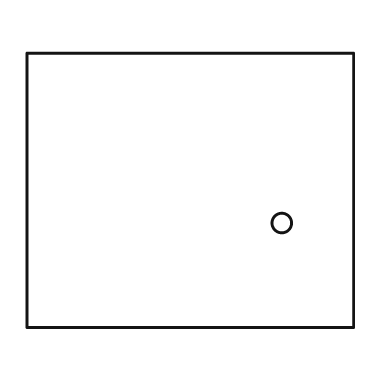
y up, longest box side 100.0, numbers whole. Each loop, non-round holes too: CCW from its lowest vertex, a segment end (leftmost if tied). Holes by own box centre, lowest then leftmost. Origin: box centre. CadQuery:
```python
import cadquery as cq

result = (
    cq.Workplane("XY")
    .moveTo(-50.0, -42.0)
    .lineTo(50.0, -42.0)
    .lineTo(50.0, 42.0)
    .lineTo(-50.0, 42.0)
    .close()
    .moveTo(28.0, -10.0)
    .circle(3.0)
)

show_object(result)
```